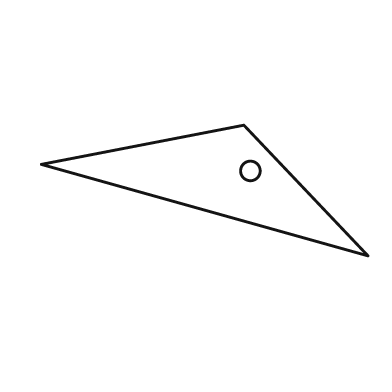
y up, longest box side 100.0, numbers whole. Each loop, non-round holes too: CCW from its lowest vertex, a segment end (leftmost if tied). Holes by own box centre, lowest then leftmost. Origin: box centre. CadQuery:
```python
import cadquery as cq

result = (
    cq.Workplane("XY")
    .moveTo(50.0, -20.0)
    .lineTo(12.0, 20.0)
    .lineTo(-50.0, 8.0)
    .close()
    .moveTo(14.0, 6.0)
    .circle(3.0)
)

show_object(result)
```